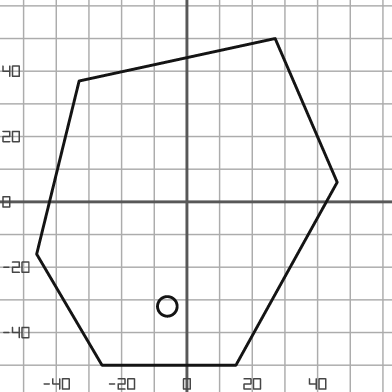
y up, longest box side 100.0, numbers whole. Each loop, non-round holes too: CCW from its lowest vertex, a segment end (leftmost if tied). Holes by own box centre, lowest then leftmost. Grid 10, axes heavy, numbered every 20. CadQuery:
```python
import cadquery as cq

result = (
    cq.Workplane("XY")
    .moveTo(-26.0, -50.0)
    .lineTo(15.0, -50.0)
    .lineTo(46.0, 6.0)
    .lineTo(27.0, 50.0)
    .lineTo(-33.0, 37.0)
    .lineTo(-46.0, -16.0)
    .close()
    .moveTo(-6.0, -32.0)
    .circle(3.0)
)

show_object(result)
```